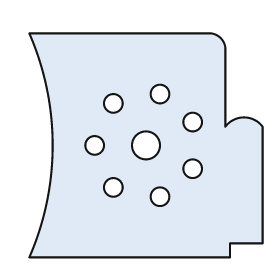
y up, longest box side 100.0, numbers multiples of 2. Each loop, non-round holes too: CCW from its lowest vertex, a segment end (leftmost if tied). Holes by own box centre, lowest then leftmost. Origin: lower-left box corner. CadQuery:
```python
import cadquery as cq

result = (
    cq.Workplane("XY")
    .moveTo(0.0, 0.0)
    .lineTo(86.0, 0.0)
    .lineTo(86.0, 6.0)
    .lineTo(100.0, 6.0)
    .lineTo(100.0, 56.0)
    .threePointArc((92.0, 60.0), (84.0, 56.0))
    .lineTo(84.0, 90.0)
    .threePointArc((82.0, 94.0), (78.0, 96.0))
    .lineTo(0.0, 96.0)
    .threePointArc((10.0, 48.0), (0.0, 0.0))
    .close()
    .moveTo(56.0, 26.0)
    .circle(4.0)
    .moveTo(36.0, 30.0)
    .circle(4.0)
    .moveTo(70.0, 38.0)
    .circle(4.0)
    .moveTo(28.0, 48.0)
    .circle(4.0)
    .moveTo(50.0, 48.0)
    .circle(6.0)
    .moveTo(70.0, 58.0)
    .circle(4.0)
    .moveTo(36.0, 66.0)
    .circle(4.0)
    .moveTo(56.0, 70.0)
    .circle(4.0)
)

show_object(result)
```